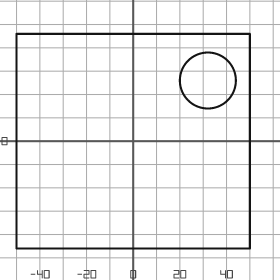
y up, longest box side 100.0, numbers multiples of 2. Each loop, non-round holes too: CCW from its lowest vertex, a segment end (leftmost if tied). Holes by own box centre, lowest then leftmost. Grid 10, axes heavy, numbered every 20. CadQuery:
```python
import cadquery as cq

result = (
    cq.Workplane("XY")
    .moveTo(-50.0, -46.0)
    .lineTo(50.0, -46.0)
    .lineTo(50.0, 46.0)
    .lineTo(-50.0, 46.0)
    .close()
    .moveTo(32.0, 26.0)
    .circle(12.0)
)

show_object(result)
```